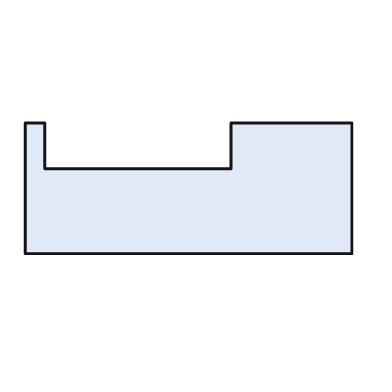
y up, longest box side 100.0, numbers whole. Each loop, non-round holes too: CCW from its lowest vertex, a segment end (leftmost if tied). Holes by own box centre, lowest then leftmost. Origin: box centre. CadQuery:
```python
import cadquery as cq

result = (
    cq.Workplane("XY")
    .moveTo(-50.0, -20.0)
    .lineTo(50.0, -20.0)
    .lineTo(50.0, 20.0)
    .lineTo(13.0, 20.0)
    .lineTo(13.0, 6.0)
    .lineTo(-44.0, 6.0)
    .lineTo(-44.0, 20.0)
    .lineTo(-50.0, 20.0)
    .close()
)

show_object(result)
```